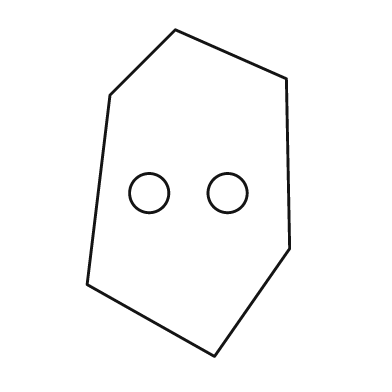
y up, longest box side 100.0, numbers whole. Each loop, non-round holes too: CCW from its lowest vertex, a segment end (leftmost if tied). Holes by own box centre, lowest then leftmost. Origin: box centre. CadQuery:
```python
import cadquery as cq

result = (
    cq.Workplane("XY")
    .moveTo(8.0, -50.0)
    .lineTo(31.0, -17.0)
    .lineTo(30.0, 35.0)
    .lineTo(-4.0, 50.0)
    .lineTo(-24.0, 30.0)
    .lineTo(-31.0, -28.0)
    .close()
    .moveTo(-12.0, 0.0)
    .circle(6.0)
    .moveTo(12.0, 0.0)
    .circle(6.0)
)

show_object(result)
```